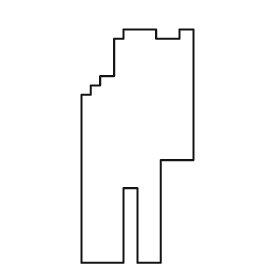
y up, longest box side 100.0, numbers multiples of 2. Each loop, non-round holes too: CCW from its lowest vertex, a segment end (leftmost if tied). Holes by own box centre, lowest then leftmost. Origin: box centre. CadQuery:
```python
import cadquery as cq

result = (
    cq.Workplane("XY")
    .moveTo(-24.0, -50.0)
    .lineTo(-6.0, -50.0)
    .lineTo(-6.0, -18.0)
    .lineTo(0.0, -18.0)
    .lineTo(0.0, -50.0)
    .lineTo(10.0, -50.0)
    .lineTo(10.0, -6.0)
    .lineTo(24.0, -6.0)
    .lineTo(24.0, 50.0)
    .lineTo(18.0, 50.0)
    .lineTo(18.0, 46.0)
    .lineTo(8.0, 46.0)
    .lineTo(8.0, 50.0)
    .lineTo(-6.0, 50.0)
    .lineTo(-6.0, 46.0)
    .lineTo(-10.0, 46.0)
    .lineTo(-10.0, 30.0)
    .lineTo(-16.0, 30.0)
    .lineTo(-16.0, 26.0)
    .lineTo(-20.0, 26.0)
    .lineTo(-20.0, 22.0)
    .lineTo(-24.0, 22.0)
    .close()
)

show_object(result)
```